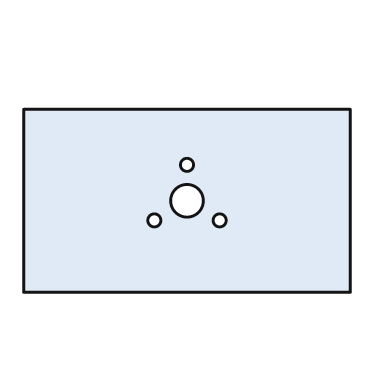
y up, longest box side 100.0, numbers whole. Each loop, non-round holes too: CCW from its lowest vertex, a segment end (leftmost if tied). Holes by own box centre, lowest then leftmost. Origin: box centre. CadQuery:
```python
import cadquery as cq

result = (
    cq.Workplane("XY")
    .moveTo(-50.0, -28.0)
    .lineTo(50.0, -28.0)
    .lineTo(50.0, 28.0)
    .lineTo(-50.0, 28.0)
    .close()
    .moveTo(-10.0, -6.0)
    .circle(2.0)
    .moveTo(10.0, -6.0)
    .circle(2.0)
    .moveTo(0.0, 0.0)
    .circle(5.0)
    .moveTo(0.0, 11.0)
    .circle(2.0)
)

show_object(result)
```